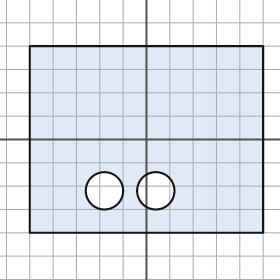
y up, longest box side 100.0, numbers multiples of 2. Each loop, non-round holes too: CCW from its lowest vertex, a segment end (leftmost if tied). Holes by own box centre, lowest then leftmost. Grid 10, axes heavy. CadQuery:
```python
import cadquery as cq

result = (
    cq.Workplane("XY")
    .moveTo(-50.0, -40.0)
    .lineTo(50.0, -40.0)
    .lineTo(50.0, 40.0)
    .lineTo(-50.0, 40.0)
    .close()
    .moveTo(-18.0, -22.0)
    .circle(8.0)
    .moveTo(4.0, -22.0)
    .circle(8.0)
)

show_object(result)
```